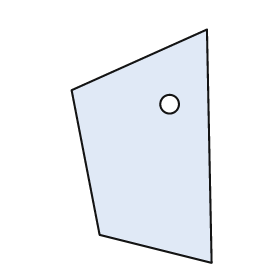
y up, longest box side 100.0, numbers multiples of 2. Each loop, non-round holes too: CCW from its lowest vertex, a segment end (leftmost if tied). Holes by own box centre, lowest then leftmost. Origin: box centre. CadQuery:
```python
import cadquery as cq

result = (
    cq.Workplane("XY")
    .moveTo(30.0, -50.0)
    .lineTo(28.0, 50.0)
    .lineTo(-30.0, 24.0)
    .lineTo(-18.0, -38.0)
    .close()
    .moveTo(12.0, 18.0)
    .circle(4.0)
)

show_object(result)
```